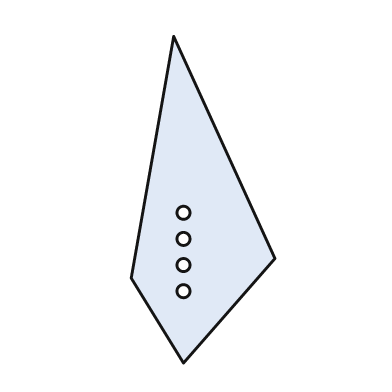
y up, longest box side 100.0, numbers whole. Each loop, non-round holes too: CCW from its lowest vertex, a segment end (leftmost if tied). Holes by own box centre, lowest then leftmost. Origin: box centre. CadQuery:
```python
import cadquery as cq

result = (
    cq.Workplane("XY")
    .moveTo(-6.0, -50.0)
    .lineTo(22.0, -18.0)
    .lineTo(-9.0, 50.0)
    .lineTo(-22.0, -24.0)
    .close()
    .moveTo(-6.0, -28.0)
    .circle(2.0)
    .moveTo(-6.0, -20.0)
    .circle(2.0)
    .moveTo(-6.0, -12.0)
    .circle(2.0)
    .moveTo(-6.0, -4.0)
    .circle(2.0)
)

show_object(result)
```